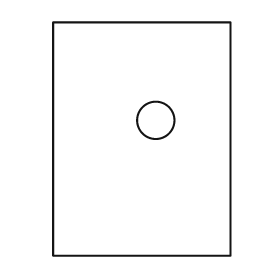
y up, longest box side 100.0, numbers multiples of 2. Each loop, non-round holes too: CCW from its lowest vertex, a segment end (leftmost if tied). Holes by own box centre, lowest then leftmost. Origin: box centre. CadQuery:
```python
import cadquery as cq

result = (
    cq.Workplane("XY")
    .moveTo(-38.0, -50.0)
    .lineTo(38.0, -50.0)
    .lineTo(38.0, 50.0)
    .lineTo(-38.0, 50.0)
    .close()
    .moveTo(6.0, 8.0)
    .circle(8.0)
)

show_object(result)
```